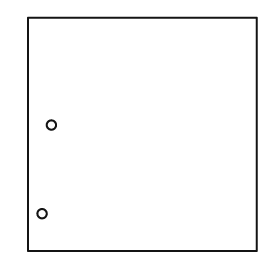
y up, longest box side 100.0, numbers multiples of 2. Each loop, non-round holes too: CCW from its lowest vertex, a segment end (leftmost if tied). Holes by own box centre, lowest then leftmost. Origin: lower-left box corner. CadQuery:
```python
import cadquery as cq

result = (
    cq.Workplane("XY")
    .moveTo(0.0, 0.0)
    .lineTo(98.0, 0.0)
    .lineTo(98.0, 100.0)
    .lineTo(0.0, 100.0)
    .close()
    .moveTo(6.0, 16.0)
    .circle(2.0)
    .moveTo(10.0, 54.0)
    .circle(2.0)
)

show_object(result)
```